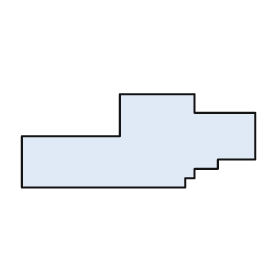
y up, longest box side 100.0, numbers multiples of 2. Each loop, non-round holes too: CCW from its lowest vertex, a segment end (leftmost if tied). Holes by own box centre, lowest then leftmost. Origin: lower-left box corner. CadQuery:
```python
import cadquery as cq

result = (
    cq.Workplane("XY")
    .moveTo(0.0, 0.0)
    .lineTo(70.0, 0.0)
    .lineTo(70.0, 4.0)
    .lineTo(74.0, 4.0)
    .lineTo(74.0, 8.0)
    .lineTo(84.0, 8.0)
    .lineTo(84.0, 12.0)
    .lineTo(100.0, 12.0)
    .lineTo(100.0, 32.0)
    .lineTo(74.0, 32.0)
    .lineTo(74.0, 40.0)
    .lineTo(42.0, 40.0)
    .lineTo(42.0, 22.0)
    .lineTo(0.0, 22.0)
    .close()
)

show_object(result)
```